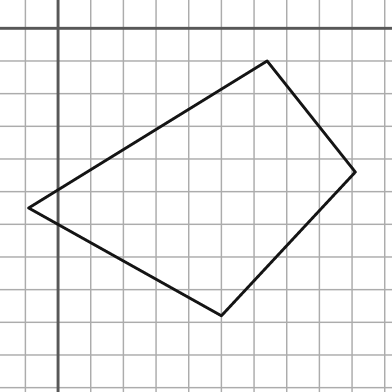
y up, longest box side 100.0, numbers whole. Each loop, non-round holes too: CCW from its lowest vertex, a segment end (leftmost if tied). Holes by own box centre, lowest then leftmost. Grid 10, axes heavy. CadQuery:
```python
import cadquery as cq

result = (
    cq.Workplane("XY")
    .moveTo(50.0, -88.0)
    .lineTo(91.0, -44.0)
    .lineTo(64.0, -10.0)
    .lineTo(-9.0, -55.0)
    .close()
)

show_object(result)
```